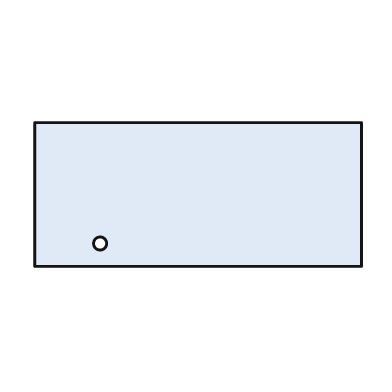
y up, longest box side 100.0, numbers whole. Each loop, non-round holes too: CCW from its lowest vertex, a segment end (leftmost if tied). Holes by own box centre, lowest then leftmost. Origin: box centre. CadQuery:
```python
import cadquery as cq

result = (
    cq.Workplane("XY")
    .moveTo(-50.0, -22.0)
    .lineTo(50.0, -22.0)
    .lineTo(50.0, 22.0)
    .lineTo(-50.0, 22.0)
    .close()
    .moveTo(-30.0, -15.0)
    .circle(2.0)
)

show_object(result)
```